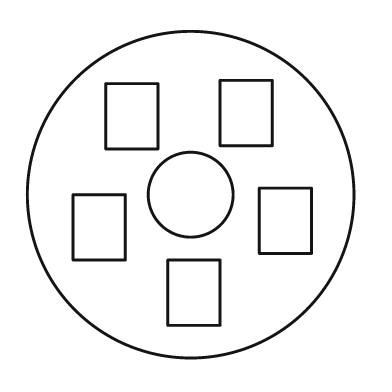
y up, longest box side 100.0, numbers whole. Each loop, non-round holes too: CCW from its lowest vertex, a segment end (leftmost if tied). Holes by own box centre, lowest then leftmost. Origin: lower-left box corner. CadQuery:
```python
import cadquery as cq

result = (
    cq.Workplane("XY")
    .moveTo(50.0, 50.0)
    .circle(50.0)
    .moveTo(43.0, 10.0)
    .lineTo(59.0, 10.0)
    .lineTo(59.0, 30.0)
    .lineTo(43.0, 30.0)
    .close()
    .moveTo(14.0, 30.0)
    .lineTo(30.0, 30.0)
    .lineTo(30.0, 50.0)
    .lineTo(14.0, 50.0)
    .close()
    .moveTo(71.0, 32.0)
    .lineTo(87.0, 32.0)
    .lineTo(87.0, 52.0)
    .lineTo(71.0, 52.0)
    .close()
    .moveTo(50.0, 50.0)
    .circle(13.0)
    .moveTo(24.0, 64.0)
    .lineTo(40.0, 64.0)
    .lineTo(40.0, 84.0)
    .lineTo(24.0, 84.0)
    .close()
    .moveTo(59.0, 65.0)
    .lineTo(75.0, 65.0)
    .lineTo(75.0, 85.0)
    .lineTo(59.0, 85.0)
    .close()
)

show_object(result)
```